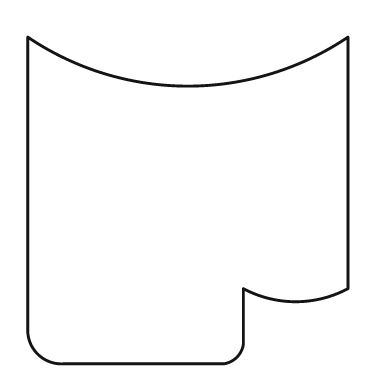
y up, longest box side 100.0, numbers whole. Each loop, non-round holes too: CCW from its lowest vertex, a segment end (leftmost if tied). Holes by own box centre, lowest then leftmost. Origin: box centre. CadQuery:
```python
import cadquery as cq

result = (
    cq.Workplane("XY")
    .moveTo(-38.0, -50.0)
    .lineTo(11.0, -50.0)
    .threePointArc((15.0, -48.0), (17.0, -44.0))
    .lineTo(17.0, -27.0)
    .threePointArc((33.0, -31.0), (49.0, -27.0))
    .lineTo(49.0, 50.0)
    .threePointArc((0.0, 35.0), (-49.0, 50.0))
    .lineTo(-49.0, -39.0)
    .threePointArc((-46.0, -47.0), (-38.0, -50.0))
    .close()
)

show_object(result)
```